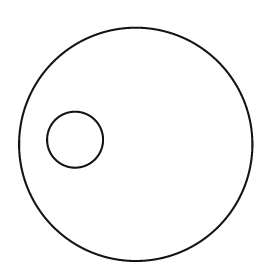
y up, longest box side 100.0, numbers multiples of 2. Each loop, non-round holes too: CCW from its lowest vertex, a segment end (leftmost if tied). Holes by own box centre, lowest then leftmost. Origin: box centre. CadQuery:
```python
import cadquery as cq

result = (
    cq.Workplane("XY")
    .moveTo(0.0, 0.0)
    .circle(50.0)
    .moveTo(-26.0, 2.0)
    .circle(12.0)
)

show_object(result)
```